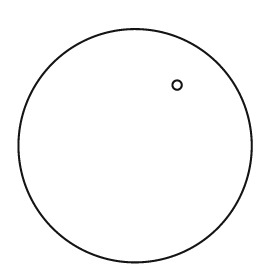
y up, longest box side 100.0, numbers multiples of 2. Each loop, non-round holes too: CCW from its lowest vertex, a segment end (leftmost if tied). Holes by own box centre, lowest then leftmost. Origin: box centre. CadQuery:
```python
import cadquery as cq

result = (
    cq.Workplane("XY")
    .moveTo(0.0, 0.0)
    .circle(50.0)
    .moveTo(18.0, 26.0)
    .circle(2.0)
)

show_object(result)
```